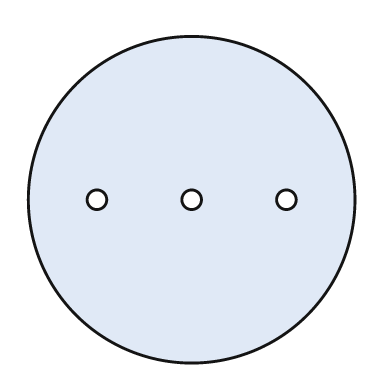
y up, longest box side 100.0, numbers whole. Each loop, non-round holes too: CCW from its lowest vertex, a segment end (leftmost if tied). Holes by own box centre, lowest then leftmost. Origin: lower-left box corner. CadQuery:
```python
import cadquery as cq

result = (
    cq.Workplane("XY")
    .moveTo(50.0, 50.0)
    .circle(50.0)
    .moveTo(21.0, 50.0)
    .circle(3.0)
    .moveTo(50.0, 50.0)
    .circle(3.0)
    .moveTo(79.0, 50.0)
    .circle(3.0)
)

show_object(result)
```